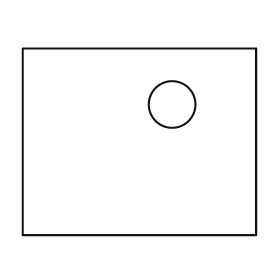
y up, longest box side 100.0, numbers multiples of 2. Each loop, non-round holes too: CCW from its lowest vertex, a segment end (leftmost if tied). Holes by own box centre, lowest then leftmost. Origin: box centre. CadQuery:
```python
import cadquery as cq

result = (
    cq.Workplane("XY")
    .moveTo(-50.0, -40.0)
    .lineTo(50.0, -40.0)
    .lineTo(50.0, 40.0)
    .lineTo(-50.0, 40.0)
    .close()
    .moveTo(14.0, 16.0)
    .circle(10.0)
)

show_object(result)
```